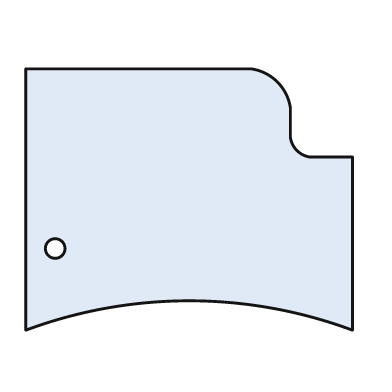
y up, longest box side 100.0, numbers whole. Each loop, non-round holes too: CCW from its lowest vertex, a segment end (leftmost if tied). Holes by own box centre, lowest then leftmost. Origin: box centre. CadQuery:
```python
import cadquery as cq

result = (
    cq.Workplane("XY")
    .moveTo(-50.0, -40.0)
    .threePointArc((0.0, -31.0), (50.0, -40.0))
    .lineTo(50.0, 13.0)
    .lineTo(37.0, 13.0)
    .threePointArc((33.0, 15.0), (31.0, 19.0))
    .lineTo(31.0, 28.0)
    .threePointArc((27.0, 36.0), (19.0, 40.0))
    .lineTo(-50.0, 40.0)
    .close()
    .moveTo(-41.0, -15.0)
    .circle(3.0)
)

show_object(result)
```